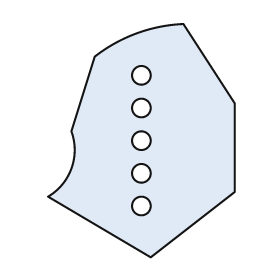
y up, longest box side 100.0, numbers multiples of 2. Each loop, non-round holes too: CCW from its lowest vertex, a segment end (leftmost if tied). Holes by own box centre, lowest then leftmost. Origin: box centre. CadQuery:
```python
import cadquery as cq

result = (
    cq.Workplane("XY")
    .moveTo(4.0, -50.0)
    .lineTo(40.0, -22.0)
    .lineTo(40.0, 16.0)
    .lineTo(18.0, 50.0)
    .threePointArc((-2.0, 46.0), (-20.0, 36.0))
    .lineTo(-30.0, 4.0)
    .threePointArc((-30.0, -12.0), (-40.0, -24.0))
    .close()
    .moveTo(0.0, -28.0)
    .circle(4.0)
    .moveTo(0.0, -14.0)
    .circle(4.0)
    .moveTo(0.0, 0.0)
    .circle(4.0)
    .moveTo(0.0, 14.0)
    .circle(4.0)
    .moveTo(0.0, 28.0)
    .circle(4.0)
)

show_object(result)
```